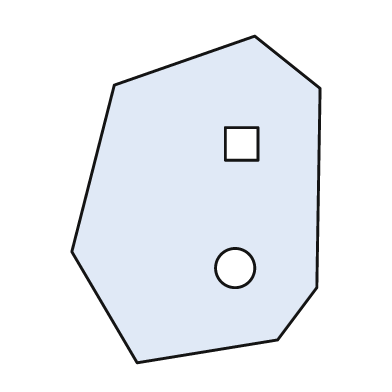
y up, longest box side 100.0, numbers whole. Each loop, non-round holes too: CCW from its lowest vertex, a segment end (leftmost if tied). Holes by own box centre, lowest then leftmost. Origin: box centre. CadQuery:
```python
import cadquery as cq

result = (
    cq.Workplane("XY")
    .moveTo(-18.0, -50.0)
    .lineTo(25.0, -43.0)
    .lineTo(37.0, -27.0)
    .lineTo(38.0, 34.0)
    .lineTo(18.0, 50.0)
    .lineTo(-25.0, 35.0)
    .lineTo(-38.0, -16.0)
    .close()
    .moveTo(12.0, -21.0)
    .circle(6.0)
    .moveTo(9.0, 12.0)
    .lineTo(19.0, 12.0)
    .lineTo(19.0, 22.0)
    .lineTo(9.0, 22.0)
    .close()
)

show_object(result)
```